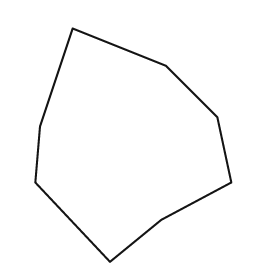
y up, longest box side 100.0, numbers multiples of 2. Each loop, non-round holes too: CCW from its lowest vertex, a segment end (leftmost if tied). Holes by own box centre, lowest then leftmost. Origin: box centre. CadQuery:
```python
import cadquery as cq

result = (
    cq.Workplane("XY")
    .moveTo(-10.0, -50.0)
    .lineTo(12.0, -32.0)
    .lineTo(42.0, -16.0)
    .lineTo(36.0, 12.0)
    .lineTo(14.0, 34.0)
    .lineTo(-26.0, 50.0)
    .lineTo(-40.0, 8.0)
    .lineTo(-42.0, -16.0)
    .close()
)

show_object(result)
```